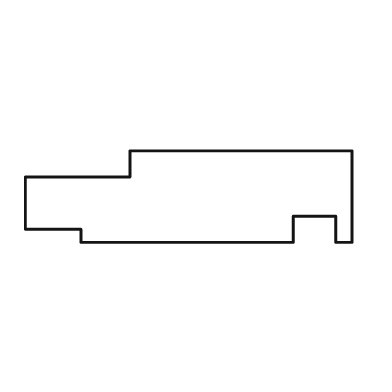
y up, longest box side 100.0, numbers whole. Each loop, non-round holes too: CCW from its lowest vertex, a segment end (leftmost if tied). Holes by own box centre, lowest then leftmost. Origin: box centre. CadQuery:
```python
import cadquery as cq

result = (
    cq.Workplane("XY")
    .moveTo(-33.0, -14.0)
    .lineTo(32.0, -14.0)
    .lineTo(32.0, -6.0)
    .lineTo(45.0, -6.0)
    .lineTo(45.0, -14.0)
    .lineTo(50.0, -14.0)
    .lineTo(50.0, 14.0)
    .lineTo(-18.0, 14.0)
    .lineTo(-18.0, 6.0)
    .lineTo(-50.0, 6.0)
    .lineTo(-50.0, -10.0)
    .lineTo(-33.0, -10.0)
    .close()
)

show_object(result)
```